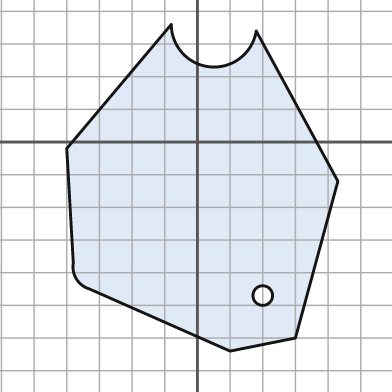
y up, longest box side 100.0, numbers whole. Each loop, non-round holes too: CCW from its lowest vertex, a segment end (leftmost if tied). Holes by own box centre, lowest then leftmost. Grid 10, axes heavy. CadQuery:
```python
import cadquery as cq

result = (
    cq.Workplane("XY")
    .moveTo(10.0, -64.0)
    .lineTo(30.0, -60.0)
    .lineTo(43.0, -12.0)
    .lineTo(18.0, 34.0)
    .threePointArc((4.0, 23.0), (-8.0, 36.0))
    .lineTo(-40.0, -2.0)
    .lineTo(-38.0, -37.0)
    .threePointArc((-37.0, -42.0), (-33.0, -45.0))
    .close()
    .moveTo(20.0, -47.0)
    .circle(3.0)
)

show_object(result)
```